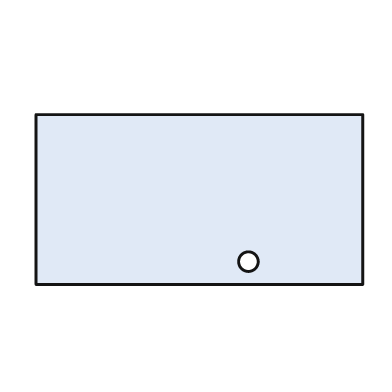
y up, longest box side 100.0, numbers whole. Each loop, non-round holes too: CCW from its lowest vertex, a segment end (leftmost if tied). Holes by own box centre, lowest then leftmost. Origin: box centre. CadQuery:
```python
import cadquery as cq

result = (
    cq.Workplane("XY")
    .moveTo(-50.0, -26.0)
    .lineTo(50.0, -26.0)
    .lineTo(50.0, 26.0)
    .lineTo(-50.0, 26.0)
    .close()
    .moveTo(15.0, -19.0)
    .circle(3.0)
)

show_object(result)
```